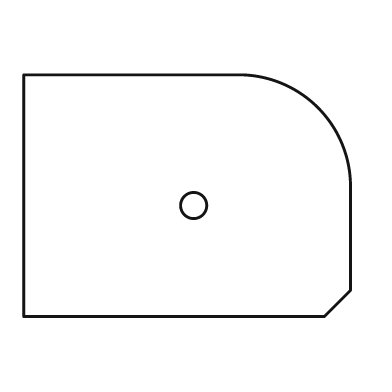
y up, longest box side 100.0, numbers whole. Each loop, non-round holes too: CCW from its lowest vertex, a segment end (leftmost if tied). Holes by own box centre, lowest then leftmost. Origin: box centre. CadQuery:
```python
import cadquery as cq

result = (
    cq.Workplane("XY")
    .moveTo(-50.0, -37.0)
    .lineTo(42.0, -37.0)
    .lineTo(50.0, -29.0)
    .lineTo(50.0, 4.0)
    .threePointArc((40.0, 27.0), (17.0, 37.0))
    .lineTo(-50.0, 37.0)
    .close()
    .moveTo(2.0, -3.0)
    .circle(4.0)
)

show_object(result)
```